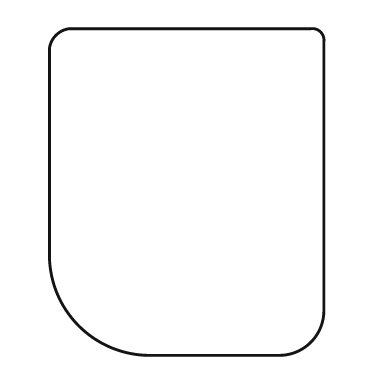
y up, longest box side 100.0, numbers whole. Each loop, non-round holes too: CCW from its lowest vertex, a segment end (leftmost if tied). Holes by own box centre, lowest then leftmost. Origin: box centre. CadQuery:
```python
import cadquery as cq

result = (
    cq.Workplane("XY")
    .moveTo(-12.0, -50.0)
    .lineTo(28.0, -50.0)
    .threePointArc((38.0, -46.0), (42.0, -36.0))
    .lineTo(42.0, 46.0)
    .threePointArc((41.0, 49.0), (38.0, 50.0))
    .lineTo(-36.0, 50.0)
    .threePointArc((-40.0, 48.0), (-42.0, 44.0))
    .lineTo(-42.0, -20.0)
    .threePointArc((-33.0, -41.0), (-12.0, -50.0))
    .close()
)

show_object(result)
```